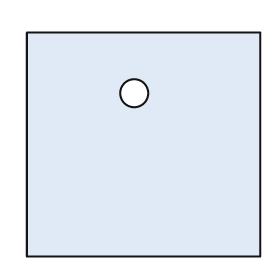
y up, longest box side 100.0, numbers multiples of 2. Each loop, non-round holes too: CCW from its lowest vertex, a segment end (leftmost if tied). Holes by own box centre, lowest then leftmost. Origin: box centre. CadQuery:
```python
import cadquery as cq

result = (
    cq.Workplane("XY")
    .moveTo(-50.0, -48.0)
    .lineTo(50.0, -48.0)
    .lineTo(50.0, 48.0)
    .lineTo(-50.0, 48.0)
    .close()
    .moveTo(-4.0, 22.0)
    .circle(6.0)
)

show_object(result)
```